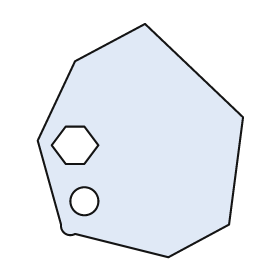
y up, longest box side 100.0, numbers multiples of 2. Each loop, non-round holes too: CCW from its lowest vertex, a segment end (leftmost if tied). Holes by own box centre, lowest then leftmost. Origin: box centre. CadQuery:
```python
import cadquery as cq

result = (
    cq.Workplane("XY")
    .moveTo(12.0, -50.0)
    .lineTo(38.0, -36.0)
    .lineTo(44.0, 10.0)
    .lineTo(2.0, 50.0)
    .lineTo(-28.0, 34.0)
    .lineTo(-44.0, 0.0)
    .lineTo(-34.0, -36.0)
    .threePointArc((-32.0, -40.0), (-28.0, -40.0))
    .close()
    .moveTo(-24.0, -26.0)
    .circle(6.0)
    .moveTo(-32.0, -10.0)
    .lineTo(-24.0, -10.0)
    .lineTo(-18.0, -2.0)
    .lineTo(-24.0, 6.0)
    .lineTo(-32.0, 6.0)
    .lineTo(-38.0, -2.0)
    .close()
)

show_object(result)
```